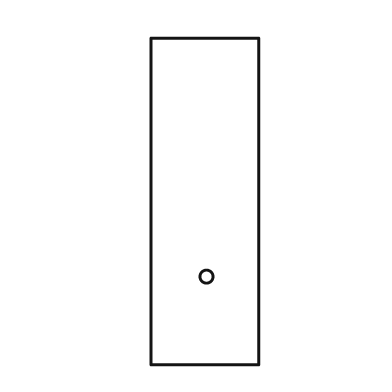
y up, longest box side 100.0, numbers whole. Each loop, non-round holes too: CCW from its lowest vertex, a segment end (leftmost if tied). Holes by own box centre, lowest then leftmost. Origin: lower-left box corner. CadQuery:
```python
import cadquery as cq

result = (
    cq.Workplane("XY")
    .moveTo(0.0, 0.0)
    .lineTo(33.0, 0.0)
    .lineTo(33.0, 100.0)
    .lineTo(0.0, 100.0)
    .close()
    .moveTo(17.0, 27.0)
    .circle(2.0)
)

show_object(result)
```